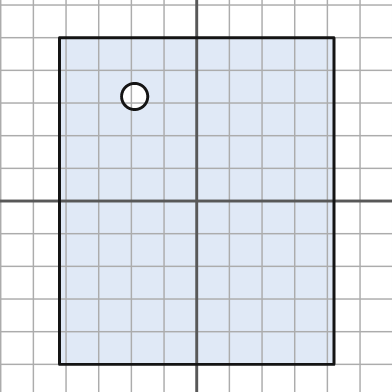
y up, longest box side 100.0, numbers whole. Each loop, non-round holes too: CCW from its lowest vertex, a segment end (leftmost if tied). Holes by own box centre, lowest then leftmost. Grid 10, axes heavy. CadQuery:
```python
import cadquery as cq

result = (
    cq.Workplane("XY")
    .moveTo(-42.0, -50.0)
    .lineTo(42.0, -50.0)
    .lineTo(42.0, 50.0)
    .lineTo(-42.0, 50.0)
    .close()
    .moveTo(-19.0, 32.0)
    .circle(4.0)
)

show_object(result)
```